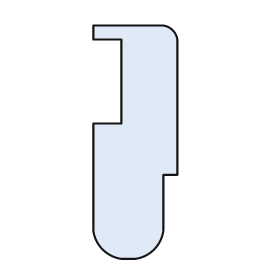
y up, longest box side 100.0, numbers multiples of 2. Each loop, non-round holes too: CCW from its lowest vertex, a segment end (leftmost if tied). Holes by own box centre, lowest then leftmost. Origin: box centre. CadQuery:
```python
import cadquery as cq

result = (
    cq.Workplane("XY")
    .moveTo(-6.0, -50.0)
    .lineTo(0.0, -50.0)
    .threePointArc((8.0, -46.0), (12.0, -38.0))
    .lineTo(12.0, -14.0)
    .lineTo(18.0, -14.0)
    .lineTo(18.0, 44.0)
    .threePointArc((16.0, 48.0), (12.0, 50.0))
    .lineTo(-18.0, 50.0)
    .lineTo(-18.0, 44.0)
    .lineTo(-6.0, 44.0)
    .lineTo(-6.0, 8.0)
    .lineTo(-18.0, 8.0)
    .lineTo(-18.0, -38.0)
    .threePointArc((-14.0, -46.0), (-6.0, -50.0))
    .close()
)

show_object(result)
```